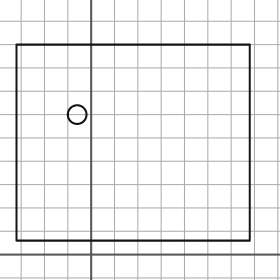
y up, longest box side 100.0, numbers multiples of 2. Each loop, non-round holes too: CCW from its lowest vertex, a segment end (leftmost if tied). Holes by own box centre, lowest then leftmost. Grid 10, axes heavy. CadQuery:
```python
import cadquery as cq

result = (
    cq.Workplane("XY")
    .moveTo(-32.0, 6.0)
    .lineTo(68.0, 6.0)
    .lineTo(68.0, 90.0)
    .lineTo(-32.0, 90.0)
    .close()
    .moveTo(-6.0, 60.0)
    .circle(4.0)
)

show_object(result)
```